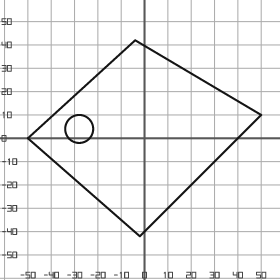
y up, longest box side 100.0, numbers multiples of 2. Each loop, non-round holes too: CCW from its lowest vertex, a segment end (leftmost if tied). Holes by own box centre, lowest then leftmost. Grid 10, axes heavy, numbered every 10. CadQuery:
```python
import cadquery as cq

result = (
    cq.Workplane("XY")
    .moveTo(-2.0, -42.0)
    .lineTo(50.0, 10.0)
    .lineTo(-4.0, 42.0)
    .lineTo(-50.0, 0.0)
    .close()
    .moveTo(-28.0, 4.0)
    .circle(6.0)
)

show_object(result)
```